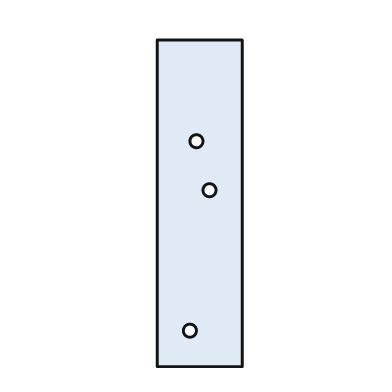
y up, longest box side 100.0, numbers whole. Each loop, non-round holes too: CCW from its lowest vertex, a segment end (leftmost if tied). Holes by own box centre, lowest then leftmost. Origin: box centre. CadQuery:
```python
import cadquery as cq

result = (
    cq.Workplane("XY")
    .moveTo(-13.0, -50.0)
    .lineTo(13.0, -50.0)
    .lineTo(13.0, 50.0)
    .lineTo(-13.0, 50.0)
    .close()
    .moveTo(-3.0, -39.0)
    .circle(2.0)
    .moveTo(3.0, 4.0)
    .circle(2.0)
    .moveTo(-1.0, 19.0)
    .circle(2.0)
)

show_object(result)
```